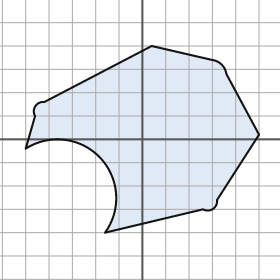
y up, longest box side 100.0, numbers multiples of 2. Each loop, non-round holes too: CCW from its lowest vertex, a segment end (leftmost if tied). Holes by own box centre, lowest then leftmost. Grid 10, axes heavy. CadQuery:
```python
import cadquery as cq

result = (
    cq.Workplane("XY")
    .moveTo(-16.0, -40.0)
    .lineTo(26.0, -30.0)
    .threePointArc((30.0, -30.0), (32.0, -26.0))
    .lineTo(50.0, 2.0)
    .lineTo(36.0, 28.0)
    .threePointArc((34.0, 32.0), (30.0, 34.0))
    .lineTo(4.0, 40.0)
    .lineTo(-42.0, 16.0)
    .threePointArc((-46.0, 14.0), (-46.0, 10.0))
    .lineTo(-50.0, -4.0)
    .threePointArc((-18.0, -8.0), (-16.0, -40.0))
    .close()
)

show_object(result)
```